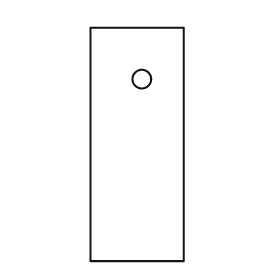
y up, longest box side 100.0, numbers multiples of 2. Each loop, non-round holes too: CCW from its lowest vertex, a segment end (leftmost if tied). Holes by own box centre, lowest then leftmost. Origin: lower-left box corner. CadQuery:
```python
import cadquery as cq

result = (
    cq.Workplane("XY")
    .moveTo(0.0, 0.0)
    .lineTo(40.0, 0.0)
    .lineTo(40.0, 100.0)
    .lineTo(0.0, 100.0)
    .close()
    .moveTo(22.0, 78.0)
    .circle(4.0)
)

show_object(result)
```